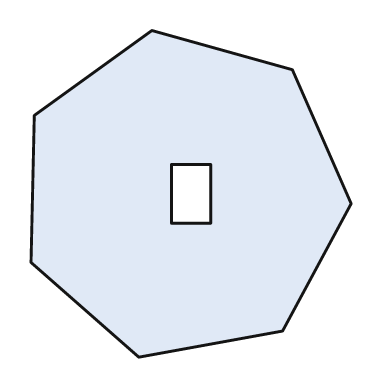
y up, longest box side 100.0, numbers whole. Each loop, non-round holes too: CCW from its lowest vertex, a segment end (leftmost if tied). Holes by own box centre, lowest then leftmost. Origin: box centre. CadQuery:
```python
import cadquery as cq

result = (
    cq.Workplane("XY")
    .moveTo(-16.0, -50.0)
    .lineTo(28.0, -42.0)
    .lineTo(49.0, -3.0)
    .lineTo(31.0, 38.0)
    .lineTo(-12.0, 50.0)
    .lineTo(-48.0, 24.0)
    .lineTo(-49.0, -21.0)
    .close()
    .moveTo(-6.0, -9.0)
    .lineTo(6.0, -9.0)
    .lineTo(6.0, 9.0)
    .lineTo(-6.0, 9.0)
    .close()
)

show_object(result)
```